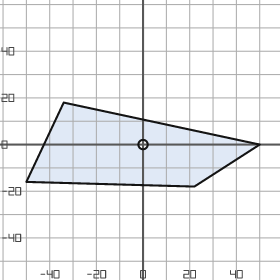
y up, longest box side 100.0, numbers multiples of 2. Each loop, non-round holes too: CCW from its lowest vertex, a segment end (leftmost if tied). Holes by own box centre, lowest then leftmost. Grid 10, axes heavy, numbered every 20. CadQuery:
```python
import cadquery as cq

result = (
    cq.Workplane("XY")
    .moveTo(22.0, -18.0)
    .lineTo(50.0, 0.0)
    .lineTo(-34.0, 18.0)
    .lineTo(-50.0, -16.0)
    .close()
    .moveTo(0.0, 0.0)
    .circle(2.0)
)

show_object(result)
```